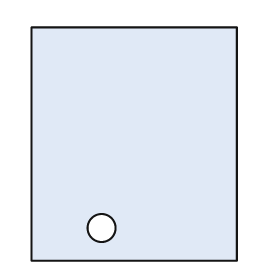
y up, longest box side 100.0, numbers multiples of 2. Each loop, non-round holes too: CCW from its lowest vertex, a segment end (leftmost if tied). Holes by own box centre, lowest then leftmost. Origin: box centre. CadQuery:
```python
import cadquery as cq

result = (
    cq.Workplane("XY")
    .moveTo(-44.0, -50.0)
    .lineTo(44.0, -50.0)
    .lineTo(44.0, 50.0)
    .lineTo(-44.0, 50.0)
    .close()
    .moveTo(-14.0, -36.0)
    .circle(6.0)
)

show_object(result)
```